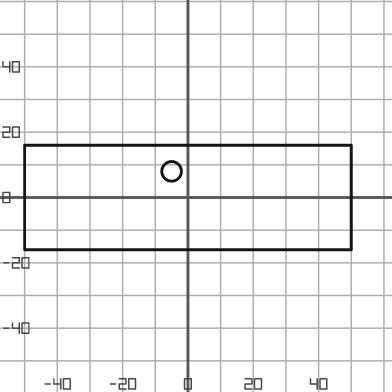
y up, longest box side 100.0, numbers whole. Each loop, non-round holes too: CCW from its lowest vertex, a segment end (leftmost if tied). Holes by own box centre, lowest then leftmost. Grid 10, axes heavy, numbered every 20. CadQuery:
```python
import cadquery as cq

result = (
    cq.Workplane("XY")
    .moveTo(-50.0, -16.0)
    .lineTo(50.0, -16.0)
    .lineTo(50.0, 16.0)
    .lineTo(-50.0, 16.0)
    .close()
    .moveTo(-5.0, 8.0)
    .circle(3.0)
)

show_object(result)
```